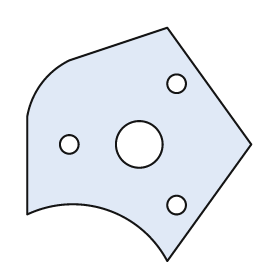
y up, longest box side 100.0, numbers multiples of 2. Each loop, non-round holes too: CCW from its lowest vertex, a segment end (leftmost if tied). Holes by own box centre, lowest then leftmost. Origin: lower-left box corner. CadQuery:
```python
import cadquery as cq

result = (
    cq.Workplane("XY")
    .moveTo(60.0, 0.0)
    .lineTo(96.0, 50.0)
    .lineTo(60.0, 100.0)
    .lineTo(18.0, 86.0)
    .threePointArc((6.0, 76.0), (0.0, 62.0))
    .lineTo(0.0, 20.0)
    .threePointArc((34.0, 22.0), (60.0, 0.0))
    .close()
    .moveTo(64.0, 24.0)
    .circle(4.0)
    .moveTo(18.0, 50.0)
    .circle(4.0)
    .moveTo(48.0, 50.0)
    .circle(10.0)
    .moveTo(64.0, 76.0)
    .circle(4.0)
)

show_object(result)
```